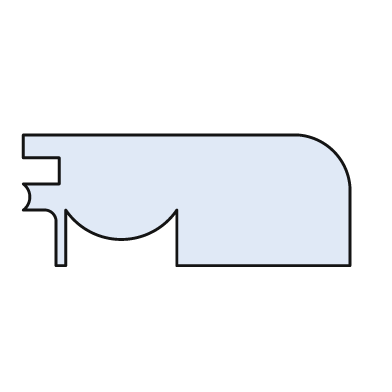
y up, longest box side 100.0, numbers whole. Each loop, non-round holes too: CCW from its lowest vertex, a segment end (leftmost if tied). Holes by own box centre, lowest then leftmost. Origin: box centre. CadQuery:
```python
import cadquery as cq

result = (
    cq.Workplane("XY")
    .moveTo(-40.0, -20.0)
    .lineTo(-37.0, -20.0)
    .lineTo(-37.0, -3.0)
    .threePointArc((-20.0, -12.0), (-3.0, -3.0))
    .lineTo(-3.0, -20.0)
    .lineTo(50.0, -20.0)
    .lineTo(50.0, 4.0)
    .threePointArc((45.0, 15.0), (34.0, 20.0))
    .lineTo(-50.0, 20.0)
    .lineTo(-50.0, 13.0)
    .lineTo(-39.0, 13.0)
    .lineTo(-39.0, 5.0)
    .lineTo(-50.0, 5.0)
    .threePointArc((-48.0, 1.0), (-50.0, -3.0))
    .lineTo(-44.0, -3.0)
    .threePointArc((-41.0, -4.0), (-40.0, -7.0))
    .close()
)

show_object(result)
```